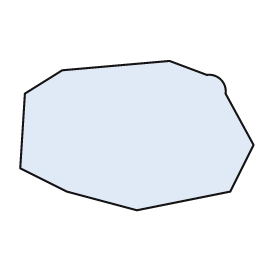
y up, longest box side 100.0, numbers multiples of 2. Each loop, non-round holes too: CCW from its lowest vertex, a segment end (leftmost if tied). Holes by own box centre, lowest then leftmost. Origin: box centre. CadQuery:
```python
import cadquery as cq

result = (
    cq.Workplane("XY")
    .moveTo(0.0, -32.0)
    .lineTo(40.0, -24.0)
    .lineTo(50.0, -4.0)
    .lineTo(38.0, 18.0)
    .threePointArc((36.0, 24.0), (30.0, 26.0))
    .lineTo(14.0, 32.0)
    .lineTo(-32.0, 28.0)
    .lineTo(-48.0, 18.0)
    .lineTo(-50.0, -14.0)
    .lineTo(-30.0, -24.0)
    .close()
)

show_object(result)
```